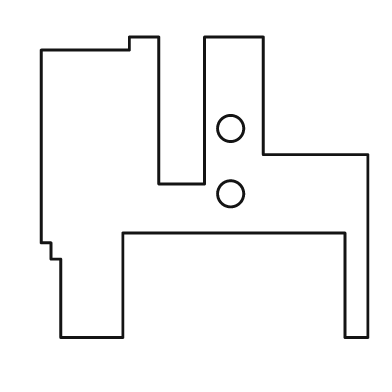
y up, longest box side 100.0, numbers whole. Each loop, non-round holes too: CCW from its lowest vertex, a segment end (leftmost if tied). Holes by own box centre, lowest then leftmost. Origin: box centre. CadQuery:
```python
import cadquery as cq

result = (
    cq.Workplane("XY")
    .moveTo(-44.0, -46.0)
    .lineTo(-25.0, -46.0)
    .lineTo(-25.0, -14.0)
    .lineTo(43.0, -14.0)
    .lineTo(43.0, -46.0)
    .lineTo(50.0, -46.0)
    .lineTo(50.0, 10.0)
    .lineTo(18.0, 10.0)
    .lineTo(18.0, 46.0)
    .lineTo(0.0, 46.0)
    .lineTo(0.0, 1.0)
    .lineTo(-14.0, 1.0)
    .lineTo(-14.0, 46.0)
    .lineTo(-23.0, 46.0)
    .lineTo(-23.0, 42.0)
    .lineTo(-50.0, 42.0)
    .lineTo(-50.0, -17.0)
    .lineTo(-47.0, -17.0)
    .lineTo(-47.0, -22.0)
    .lineTo(-44.0, -22.0)
    .close()
    .moveTo(8.0, -2.0)
    .circle(4.0)
    .moveTo(8.0, 18.0)
    .circle(4.0)
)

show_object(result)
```